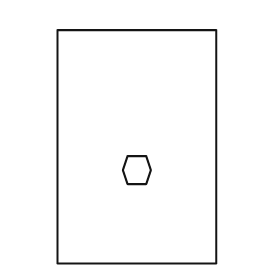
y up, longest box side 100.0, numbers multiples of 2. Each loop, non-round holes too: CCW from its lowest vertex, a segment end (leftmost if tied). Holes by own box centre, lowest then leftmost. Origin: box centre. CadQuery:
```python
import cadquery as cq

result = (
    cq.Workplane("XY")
    .moveTo(-34.0, -50.0)
    .lineTo(34.0, -50.0)
    .lineTo(34.0, 50.0)
    .lineTo(-34.0, 50.0)
    .close()
    .moveTo(-4.0, -16.0)
    .lineTo(4.0, -16.0)
    .lineTo(6.0, -10.0)
    .lineTo(4.0, -4.0)
    .lineTo(-4.0, -4.0)
    .lineTo(-6.0, -10.0)
    .close()
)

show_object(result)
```